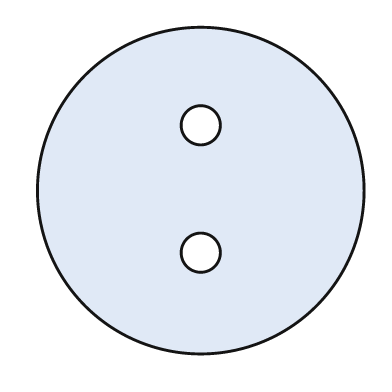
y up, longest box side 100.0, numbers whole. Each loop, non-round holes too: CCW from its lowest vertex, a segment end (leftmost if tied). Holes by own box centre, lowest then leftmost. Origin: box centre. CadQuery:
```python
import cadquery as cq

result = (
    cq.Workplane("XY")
    .moveTo(0.0, 0.0)
    .circle(50.0)
    .moveTo(0.0, -19.0)
    .circle(6.0)
    .moveTo(0.0, 20.0)
    .circle(6.0)
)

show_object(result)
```